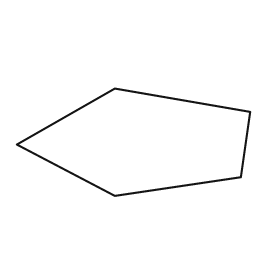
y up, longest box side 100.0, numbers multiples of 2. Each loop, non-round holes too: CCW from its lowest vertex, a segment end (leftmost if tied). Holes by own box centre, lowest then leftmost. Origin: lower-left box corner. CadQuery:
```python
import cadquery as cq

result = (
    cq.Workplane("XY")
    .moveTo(42.0, 0.0)
    .lineTo(96.0, 8.0)
    .lineTo(100.0, 36.0)
    .lineTo(42.0, 46.0)
    .lineTo(0.0, 22.0)
    .close()
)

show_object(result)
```